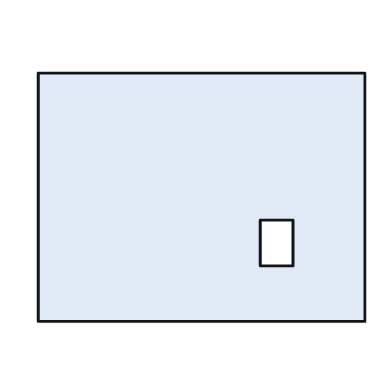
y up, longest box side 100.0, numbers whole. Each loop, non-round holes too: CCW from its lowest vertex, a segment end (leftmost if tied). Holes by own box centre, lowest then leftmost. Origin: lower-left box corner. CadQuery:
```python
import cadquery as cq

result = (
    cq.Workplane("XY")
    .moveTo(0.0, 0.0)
    .lineTo(100.0, 0.0)
    .lineTo(100.0, 76.0)
    .lineTo(0.0, 76.0)
    .close()
    .moveTo(68.0, 17.0)
    .lineTo(78.0, 17.0)
    .lineTo(78.0, 31.0)
    .lineTo(68.0, 31.0)
    .close()
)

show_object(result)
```